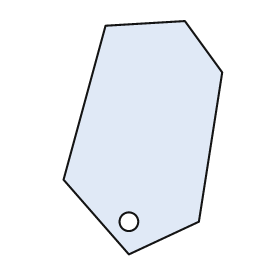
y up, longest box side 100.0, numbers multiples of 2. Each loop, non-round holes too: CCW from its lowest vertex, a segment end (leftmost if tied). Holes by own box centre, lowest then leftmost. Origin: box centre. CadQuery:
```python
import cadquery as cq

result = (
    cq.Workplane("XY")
    .moveTo(-6.0, -50.0)
    .lineTo(24.0, -36.0)
    .lineTo(34.0, 28.0)
    .lineTo(18.0, 50.0)
    .lineTo(-16.0, 48.0)
    .lineTo(-34.0, -18.0)
    .close()
    .moveTo(-6.0, -36.0)
    .circle(4.0)
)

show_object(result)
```